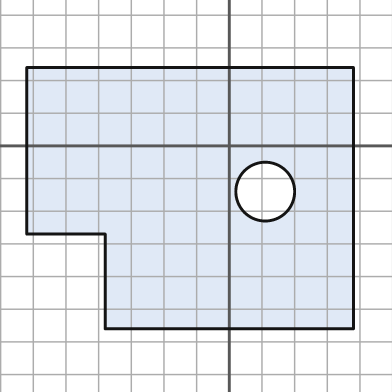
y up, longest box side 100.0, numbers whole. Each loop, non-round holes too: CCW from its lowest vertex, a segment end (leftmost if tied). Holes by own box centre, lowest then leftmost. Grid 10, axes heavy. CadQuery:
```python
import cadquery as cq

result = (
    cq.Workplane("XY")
    .moveTo(-38.0, -56.0)
    .lineTo(38.0, -56.0)
    .lineTo(38.0, 24.0)
    .lineTo(-62.0, 24.0)
    .lineTo(-62.0, -27.0)
    .lineTo(-38.0, -27.0)
    .close()
    .moveTo(11.0, -14.0)
    .circle(9.0)
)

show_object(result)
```